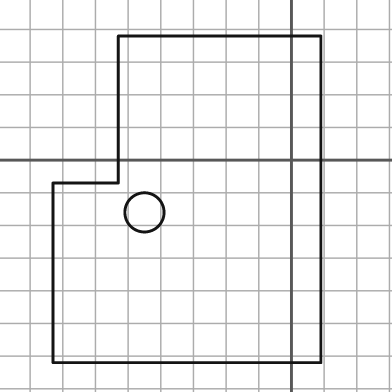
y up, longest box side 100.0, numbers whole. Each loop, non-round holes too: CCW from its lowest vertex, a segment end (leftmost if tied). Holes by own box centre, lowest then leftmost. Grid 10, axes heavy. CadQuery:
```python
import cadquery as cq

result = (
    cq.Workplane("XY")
    .moveTo(-73.0, -62.0)
    .lineTo(9.0, -62.0)
    .lineTo(9.0, 38.0)
    .lineTo(-53.0, 38.0)
    .lineTo(-53.0, -7.0)
    .lineTo(-73.0, -7.0)
    .close()
    .moveTo(-45.0, -16.0)
    .circle(6.0)
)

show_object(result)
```